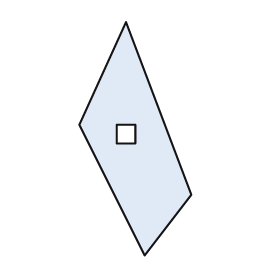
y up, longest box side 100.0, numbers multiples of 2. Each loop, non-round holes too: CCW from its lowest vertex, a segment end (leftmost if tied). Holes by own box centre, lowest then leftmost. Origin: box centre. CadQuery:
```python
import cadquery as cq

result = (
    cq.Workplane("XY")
    .moveTo(4.0, -50.0)
    .lineTo(24.0, -24.0)
    .lineTo(-4.0, 50.0)
    .lineTo(-24.0, 6.0)
    .close()
    .moveTo(-8.0, -2.0)
    .lineTo(0.0, -2.0)
    .lineTo(0.0, 6.0)
    .lineTo(-8.0, 6.0)
    .close()
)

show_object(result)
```